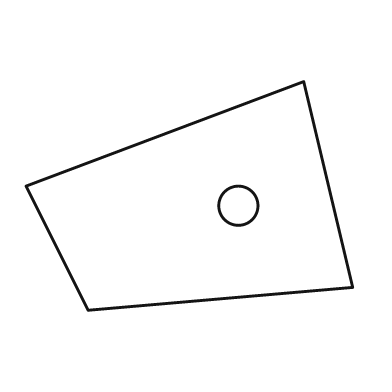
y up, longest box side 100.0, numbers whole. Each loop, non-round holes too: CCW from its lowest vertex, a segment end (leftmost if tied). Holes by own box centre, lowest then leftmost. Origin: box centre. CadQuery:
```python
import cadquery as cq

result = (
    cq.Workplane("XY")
    .moveTo(-31.0, -35.0)
    .lineTo(50.0, -28.0)
    .lineTo(35.0, 35.0)
    .lineTo(-50.0, 3.0)
    .close()
    .moveTo(15.0, -3.0)
    .circle(6.0)
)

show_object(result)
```